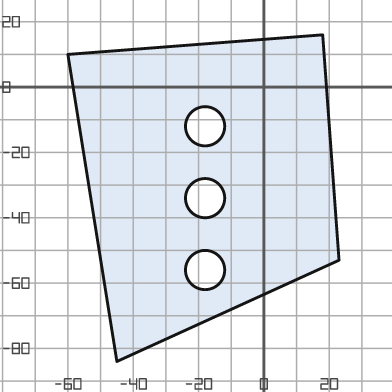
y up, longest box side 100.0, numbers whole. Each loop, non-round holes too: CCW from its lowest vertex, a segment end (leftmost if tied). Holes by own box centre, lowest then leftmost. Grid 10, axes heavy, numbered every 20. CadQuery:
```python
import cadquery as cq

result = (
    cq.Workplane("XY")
    .moveTo(-45.0, -84.0)
    .lineTo(23.0, -53.0)
    .lineTo(18.0, 16.0)
    .lineTo(-60.0, 10.0)
    .close()
    .moveTo(-18.0, -56.0)
    .circle(6.0)
    .moveTo(-18.0, -34.0)
    .circle(6.0)
    .moveTo(-18.0, -12.0)
    .circle(6.0)
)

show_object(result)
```